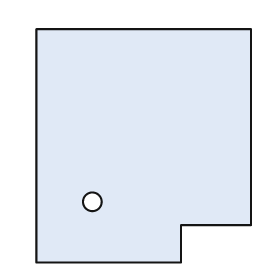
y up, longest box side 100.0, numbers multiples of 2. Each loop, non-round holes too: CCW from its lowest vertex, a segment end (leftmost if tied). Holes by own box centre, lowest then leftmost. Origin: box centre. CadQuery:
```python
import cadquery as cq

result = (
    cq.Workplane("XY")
    .moveTo(-46.0, -50.0)
    .lineTo(16.0, -50.0)
    .lineTo(16.0, -34.0)
    .lineTo(46.0, -34.0)
    .lineTo(46.0, 50.0)
    .lineTo(-46.0, 50.0)
    .close()
    .moveTo(-22.0, -24.0)
    .circle(4.0)
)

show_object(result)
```